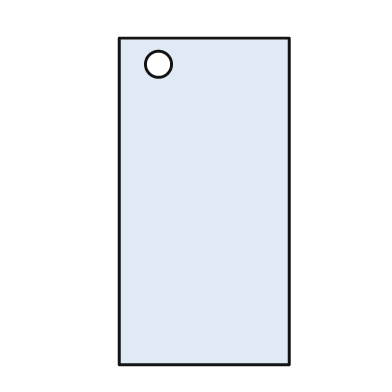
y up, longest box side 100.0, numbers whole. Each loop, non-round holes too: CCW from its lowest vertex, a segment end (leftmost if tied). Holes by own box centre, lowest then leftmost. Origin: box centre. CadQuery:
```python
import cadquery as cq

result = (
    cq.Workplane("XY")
    .moveTo(-26.0, -50.0)
    .lineTo(26.0, -50.0)
    .lineTo(26.0, 50.0)
    .lineTo(-26.0, 50.0)
    .close()
    .moveTo(-14.0, 42.0)
    .circle(4.0)
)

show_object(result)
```